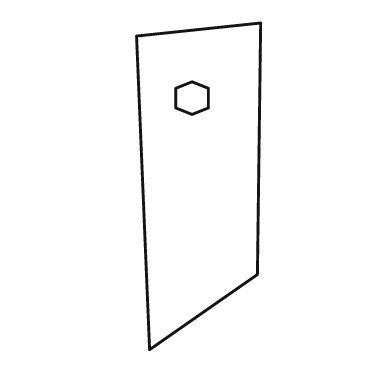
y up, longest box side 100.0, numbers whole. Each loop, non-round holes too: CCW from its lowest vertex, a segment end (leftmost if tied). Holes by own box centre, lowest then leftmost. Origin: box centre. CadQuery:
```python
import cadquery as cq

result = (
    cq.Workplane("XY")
    .moveTo(-15.0, -50.0)
    .lineTo(18.0, -27.0)
    .lineTo(19.0, 50.0)
    .lineTo(-19.0, 46.0)
    .close()
    .moveTo(-2.0, 22.0)
    .lineTo(3.0, 24.0)
    .lineTo(3.0, 30.0)
    .lineTo(-2.0, 32.0)
    .lineTo(-7.0, 30.0)
    .lineTo(-7.0, 24.0)
    .close()
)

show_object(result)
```